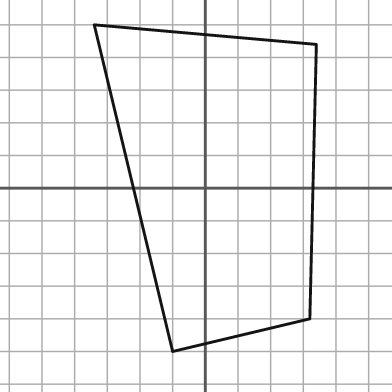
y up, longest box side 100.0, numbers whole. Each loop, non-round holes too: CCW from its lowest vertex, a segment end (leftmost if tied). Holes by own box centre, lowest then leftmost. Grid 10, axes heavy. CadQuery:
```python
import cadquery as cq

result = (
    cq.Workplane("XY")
    .moveTo(-10.0, -50.0)
    .lineTo(32.0, -40.0)
    .lineTo(34.0, 44.0)
    .lineTo(-34.0, 50.0)
    .close()
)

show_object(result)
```